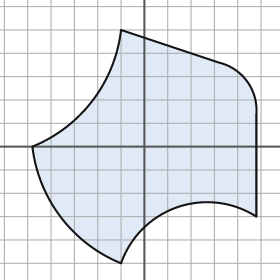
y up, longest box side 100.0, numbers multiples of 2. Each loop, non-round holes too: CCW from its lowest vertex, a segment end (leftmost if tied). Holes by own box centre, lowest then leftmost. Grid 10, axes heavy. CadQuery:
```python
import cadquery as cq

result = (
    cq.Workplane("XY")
    .moveTo(-10.0, -50.0)
    .threePointArc((14.0, -26.0), (48.0, -30.0))
    .lineTo(48.0, 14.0)
    .threePointArc((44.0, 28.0), (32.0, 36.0))
    .lineTo(-10.0, 50.0)
    .threePointArc((-22.0, 20.0), (-48.0, 0.0))
    .threePointArc((-36.0, -30.0), (-10.0, -50.0))
    .close()
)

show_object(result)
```